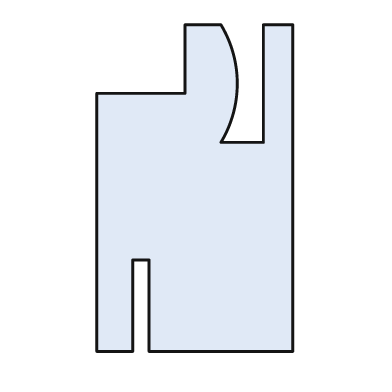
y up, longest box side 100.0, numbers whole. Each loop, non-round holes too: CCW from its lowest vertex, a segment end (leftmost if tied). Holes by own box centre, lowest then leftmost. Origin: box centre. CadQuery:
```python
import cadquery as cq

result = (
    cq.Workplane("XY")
    .moveTo(-30.0, -50.0)
    .lineTo(-19.0, -50.0)
    .lineTo(-19.0, -22.0)
    .lineTo(-14.0, -22.0)
    .lineTo(-14.0, -50.0)
    .lineTo(30.0, -50.0)
    .lineTo(30.0, 50.0)
    .lineTo(21.0, 50.0)
    .lineTo(21.0, 14.0)
    .lineTo(8.0, 14.0)
    .threePointArc((13.0, 32.0), (8.0, 50.0))
    .lineTo(-3.0, 50.0)
    .lineTo(-3.0, 29.0)
    .lineTo(-30.0, 29.0)
    .close()
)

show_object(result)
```